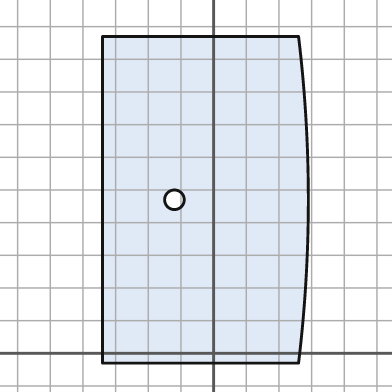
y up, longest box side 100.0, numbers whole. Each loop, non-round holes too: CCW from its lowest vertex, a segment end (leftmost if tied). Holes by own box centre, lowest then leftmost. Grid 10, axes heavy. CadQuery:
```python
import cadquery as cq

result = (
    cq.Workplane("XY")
    .moveTo(-34.0, -3.0)
    .lineTo(26.0, -3.0)
    .threePointArc((29.0, 47.0), (26.0, 97.0))
    .lineTo(-34.0, 97.0)
    .close()
    .moveTo(-12.0, 47.0)
    .circle(3.0)
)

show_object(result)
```